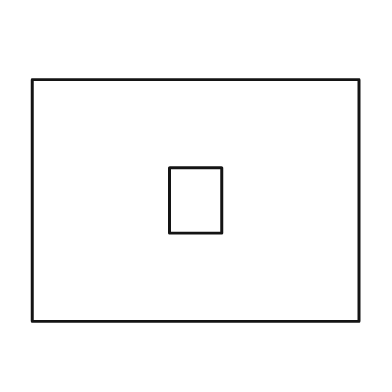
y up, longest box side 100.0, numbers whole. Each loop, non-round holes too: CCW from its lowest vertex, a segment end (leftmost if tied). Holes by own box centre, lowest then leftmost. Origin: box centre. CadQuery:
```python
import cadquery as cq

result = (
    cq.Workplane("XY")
    .moveTo(-50.0, -37.0)
    .lineTo(50.0, -37.0)
    .lineTo(50.0, 37.0)
    .lineTo(-50.0, 37.0)
    .close()
    .moveTo(-8.0, -10.0)
    .lineTo(8.0, -10.0)
    .lineTo(8.0, 10.0)
    .lineTo(-8.0, 10.0)
    .close()
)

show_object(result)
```